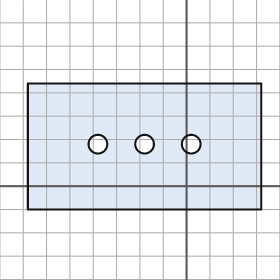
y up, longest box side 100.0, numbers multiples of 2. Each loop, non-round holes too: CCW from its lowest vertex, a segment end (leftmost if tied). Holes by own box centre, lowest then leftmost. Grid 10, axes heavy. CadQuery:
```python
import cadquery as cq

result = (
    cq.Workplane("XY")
    .moveTo(-68.0, -10.0)
    .lineTo(32.0, -10.0)
    .lineTo(32.0, 44.0)
    .lineTo(-68.0, 44.0)
    .close()
    .moveTo(-38.0, 18.0)
    .circle(4.0)
    .moveTo(-18.0, 18.0)
    .circle(4.0)
    .moveTo(2.0, 18.0)
    .circle(4.0)
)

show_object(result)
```